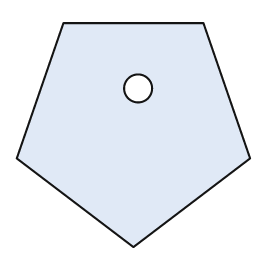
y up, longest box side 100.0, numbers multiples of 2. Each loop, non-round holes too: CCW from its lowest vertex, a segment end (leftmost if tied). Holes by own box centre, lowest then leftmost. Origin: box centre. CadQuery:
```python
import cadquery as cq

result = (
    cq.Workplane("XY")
    .moveTo(0.0, -48.0)
    .lineTo(50.0, -10.0)
    .lineTo(30.0, 48.0)
    .lineTo(-30.0, 48.0)
    .lineTo(-50.0, -10.0)
    .close()
    .moveTo(2.0, 20.0)
    .circle(6.0)
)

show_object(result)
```